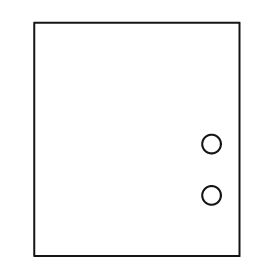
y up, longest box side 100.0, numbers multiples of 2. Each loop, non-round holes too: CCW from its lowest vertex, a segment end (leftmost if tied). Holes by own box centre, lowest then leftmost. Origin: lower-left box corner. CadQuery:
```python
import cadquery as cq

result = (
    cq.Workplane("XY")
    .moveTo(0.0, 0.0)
    .lineTo(88.0, 0.0)
    .lineTo(88.0, 100.0)
    .lineTo(0.0, 100.0)
    .close()
    .moveTo(76.0, 26.0)
    .circle(4.0)
    .moveTo(76.0, 48.0)
    .circle(4.0)
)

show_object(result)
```